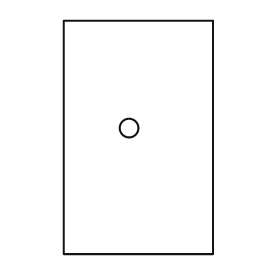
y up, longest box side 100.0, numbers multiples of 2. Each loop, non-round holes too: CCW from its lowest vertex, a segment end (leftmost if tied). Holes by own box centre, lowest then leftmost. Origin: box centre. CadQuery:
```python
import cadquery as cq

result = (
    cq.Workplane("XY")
    .moveTo(-32.0, -50.0)
    .lineTo(32.0, -50.0)
    .lineTo(32.0, 50.0)
    .lineTo(-32.0, 50.0)
    .close()
    .moveTo(-4.0, 4.0)
    .circle(4.0)
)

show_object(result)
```